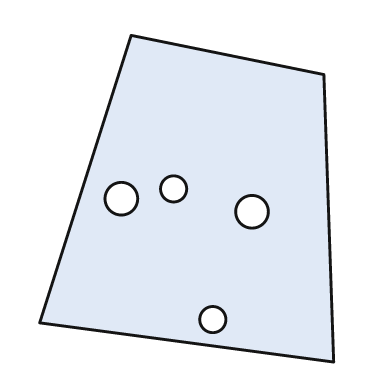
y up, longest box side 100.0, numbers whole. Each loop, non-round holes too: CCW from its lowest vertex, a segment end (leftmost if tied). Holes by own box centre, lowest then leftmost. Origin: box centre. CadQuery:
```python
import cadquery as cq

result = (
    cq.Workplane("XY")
    .moveTo(45.0, -50.0)
    .lineTo(42.0, 38.0)
    .lineTo(-17.0, 50.0)
    .lineTo(-45.0, -38.0)
    .close()
    .moveTo(8.0, -37.0)
    .circle(4.0)
    .moveTo(20.0, -4.0)
    .circle(5.0)
    .moveTo(-20.0, 0.0)
    .circle(5.0)
    .moveTo(-4.0, 3.0)
    .circle(4.0)
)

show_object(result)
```